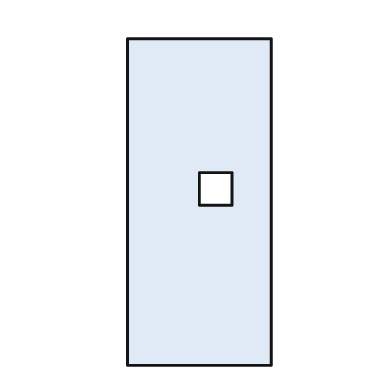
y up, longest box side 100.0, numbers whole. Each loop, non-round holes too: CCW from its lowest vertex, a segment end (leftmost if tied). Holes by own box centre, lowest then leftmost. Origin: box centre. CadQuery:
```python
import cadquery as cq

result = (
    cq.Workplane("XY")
    .moveTo(-22.0, -50.0)
    .lineTo(22.0, -50.0)
    .lineTo(22.0, 50.0)
    .lineTo(-22.0, 50.0)
    .close()
    .moveTo(0.0, -1.0)
    .lineTo(10.0, -1.0)
    .lineTo(10.0, 9.0)
    .lineTo(0.0, 9.0)
    .close()
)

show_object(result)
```